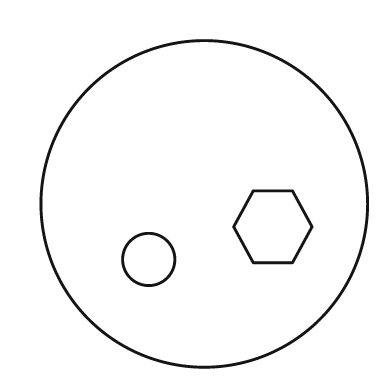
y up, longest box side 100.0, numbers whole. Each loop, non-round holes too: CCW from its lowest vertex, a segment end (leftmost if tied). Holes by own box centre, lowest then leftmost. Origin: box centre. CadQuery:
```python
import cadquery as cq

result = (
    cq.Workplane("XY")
    .moveTo(0.0, 0.0)
    .circle(50.0)
    .moveTo(-17.0, -17.0)
    .circle(8.0)
    .moveTo(15.0, -18.0)
    .lineTo(27.0, -18.0)
    .lineTo(33.0, -7.0)
    .lineTo(27.0, 4.0)
    .lineTo(15.0, 4.0)
    .lineTo(9.0, -7.0)
    .close()
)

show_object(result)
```